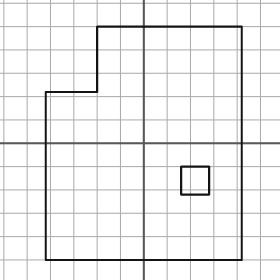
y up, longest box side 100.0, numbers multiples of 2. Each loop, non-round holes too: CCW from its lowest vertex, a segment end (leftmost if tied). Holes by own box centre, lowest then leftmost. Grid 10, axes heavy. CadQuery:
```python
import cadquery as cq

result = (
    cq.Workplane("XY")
    .moveTo(-42.0, -50.0)
    .lineTo(42.0, -50.0)
    .lineTo(42.0, 50.0)
    .lineTo(-20.0, 50.0)
    .lineTo(-20.0, 22.0)
    .lineTo(-42.0, 22.0)
    .close()
    .moveTo(16.0, -22.0)
    .lineTo(28.0, -22.0)
    .lineTo(28.0, -10.0)
    .lineTo(16.0, -10.0)
    .close()
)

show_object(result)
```